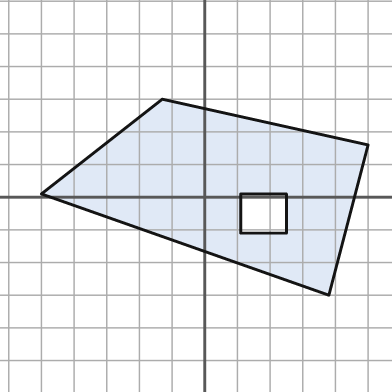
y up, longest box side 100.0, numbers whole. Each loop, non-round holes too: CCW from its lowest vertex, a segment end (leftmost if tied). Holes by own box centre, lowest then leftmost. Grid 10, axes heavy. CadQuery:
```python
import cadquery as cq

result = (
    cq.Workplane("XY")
    .moveTo(38.0, -30.0)
    .lineTo(50.0, 16.0)
    .lineTo(-13.0, 30.0)
    .lineTo(-50.0, 1.0)
    .close()
    .moveTo(11.0, -11.0)
    .lineTo(25.0, -11.0)
    .lineTo(25.0, 1.0)
    .lineTo(11.0, 1.0)
    .close()
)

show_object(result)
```